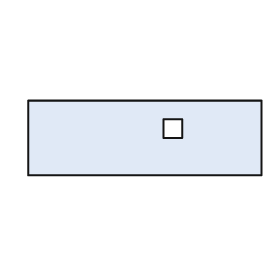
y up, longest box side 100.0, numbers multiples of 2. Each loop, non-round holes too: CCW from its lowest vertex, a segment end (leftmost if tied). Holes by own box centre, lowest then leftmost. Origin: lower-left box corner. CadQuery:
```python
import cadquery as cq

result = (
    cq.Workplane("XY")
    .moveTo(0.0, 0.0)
    .lineTo(100.0, 0.0)
    .lineTo(100.0, 32.0)
    .lineTo(0.0, 32.0)
    .close()
    .moveTo(58.0, 16.0)
    .lineTo(66.0, 16.0)
    .lineTo(66.0, 24.0)
    .lineTo(58.0, 24.0)
    .close()
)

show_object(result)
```